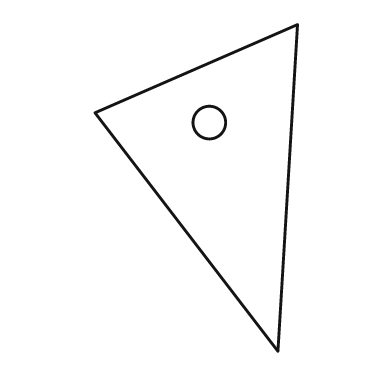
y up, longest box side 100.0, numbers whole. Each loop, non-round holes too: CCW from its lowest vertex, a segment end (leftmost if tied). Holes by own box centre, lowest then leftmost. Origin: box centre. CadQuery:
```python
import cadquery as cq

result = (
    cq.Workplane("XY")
    .moveTo(25.0, -50.0)
    .lineTo(31.0, 50.0)
    .lineTo(-31.0, 23.0)
    .close()
    .moveTo(4.0, 20.0)
    .circle(5.0)
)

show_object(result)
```